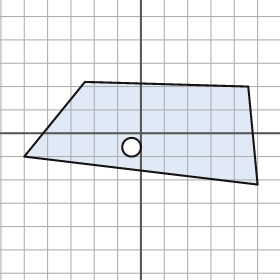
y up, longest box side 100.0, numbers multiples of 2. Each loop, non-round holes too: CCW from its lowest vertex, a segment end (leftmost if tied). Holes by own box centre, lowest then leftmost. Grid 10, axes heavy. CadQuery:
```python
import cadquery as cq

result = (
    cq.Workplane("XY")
    .moveTo(50.0, -22.0)
    .lineTo(46.0, 20.0)
    .lineTo(-24.0, 22.0)
    .lineTo(-50.0, -10.0)
    .close()
    .moveTo(-4.0, -6.0)
    .circle(4.0)
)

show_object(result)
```